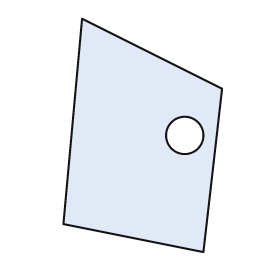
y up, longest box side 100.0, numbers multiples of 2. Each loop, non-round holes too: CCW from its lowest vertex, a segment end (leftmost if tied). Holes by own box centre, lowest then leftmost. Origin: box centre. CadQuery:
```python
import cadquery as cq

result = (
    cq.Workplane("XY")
    .moveTo(26.0, -50.0)
    .lineTo(34.0, 20.0)
    .lineTo(-26.0, 50.0)
    .lineTo(-34.0, -38.0)
    .close()
    .moveTo(18.0, 0.0)
    .circle(8.0)
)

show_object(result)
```